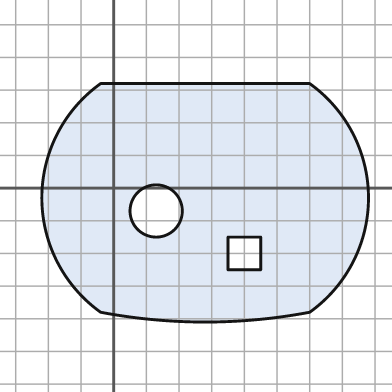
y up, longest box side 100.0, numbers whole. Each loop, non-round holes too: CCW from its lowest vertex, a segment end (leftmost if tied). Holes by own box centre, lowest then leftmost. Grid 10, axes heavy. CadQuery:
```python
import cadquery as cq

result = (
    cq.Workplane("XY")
    .moveTo(-4.0, -38.0)
    .threePointArc((28.0, -41.0), (60.0, -38.0))
    .threePointArc((78.0, -3.0), (60.0, 32.0))
    .lineTo(-4.0, 32.0)
    .threePointArc((-22.0, -3.0), (-4.0, -38.0))
    .close()
    .moveTo(35.0, -25.0)
    .lineTo(45.0, -25.0)
    .lineTo(45.0, -15.0)
    .lineTo(35.0, -15.0)
    .close()
    .moveTo(13.0, -7.0)
    .circle(8.0)
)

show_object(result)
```